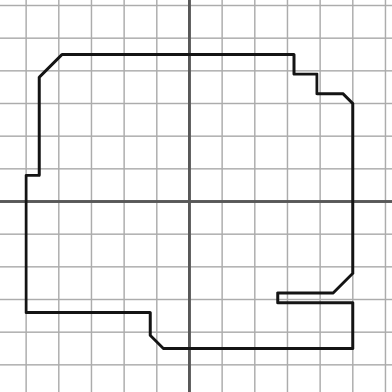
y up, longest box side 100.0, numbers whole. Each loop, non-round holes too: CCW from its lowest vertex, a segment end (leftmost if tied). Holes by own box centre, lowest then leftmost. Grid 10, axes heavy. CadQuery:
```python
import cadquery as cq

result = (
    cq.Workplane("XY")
    .moveTo(-8.0, -45.0)
    .lineTo(50.0, -45.0)
    .lineTo(50.0, -31.0)
    .lineTo(27.0, -31.0)
    .lineTo(27.0, -28.0)
    .lineTo(44.0, -28.0)
    .lineTo(50.0, -22.0)
    .lineTo(50.0, 30.0)
    .lineTo(47.0, 33.0)
    .lineTo(39.0, 33.0)
    .lineTo(39.0, 39.0)
    .lineTo(32.0, 39.0)
    .lineTo(32.0, 45.0)
    .lineTo(-39.0, 45.0)
    .lineTo(-46.0, 38.0)
    .lineTo(-46.0, 8.0)
    .lineTo(-50.0, 8.0)
    .lineTo(-50.0, -34.0)
    .lineTo(-12.0, -34.0)
    .lineTo(-12.0, -41.0)
    .close()
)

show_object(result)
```